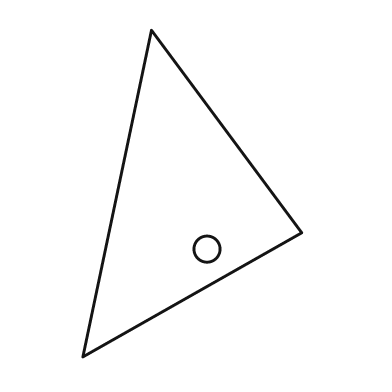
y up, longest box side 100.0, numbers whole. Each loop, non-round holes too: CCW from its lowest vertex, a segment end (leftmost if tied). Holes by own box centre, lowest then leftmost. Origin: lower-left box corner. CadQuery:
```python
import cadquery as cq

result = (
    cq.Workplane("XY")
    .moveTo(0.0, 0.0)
    .lineTo(67.0, 38.0)
    .lineTo(21.0, 100.0)
    .close()
    .moveTo(38.0, 33.0)
    .circle(4.0)
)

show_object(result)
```